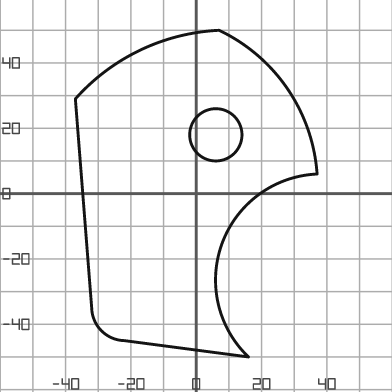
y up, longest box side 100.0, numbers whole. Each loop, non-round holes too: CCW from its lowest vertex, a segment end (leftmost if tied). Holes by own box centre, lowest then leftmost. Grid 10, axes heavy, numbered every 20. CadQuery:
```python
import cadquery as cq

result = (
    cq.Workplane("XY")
    .moveTo(16.0, -50.0)
    .threePointArc((8.0, -15.0), (37.0, 6.0))
    .threePointArc((28.0, 32.0), (7.0, 50.0))
    .threePointArc((-17.0, 44.0), (-37.0, 29.0))
    .lineTo(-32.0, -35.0)
    .threePointArc((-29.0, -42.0), (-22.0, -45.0))
    .close()
    .moveTo(6.0, 18.0)
    .circle(8.0)
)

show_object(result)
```